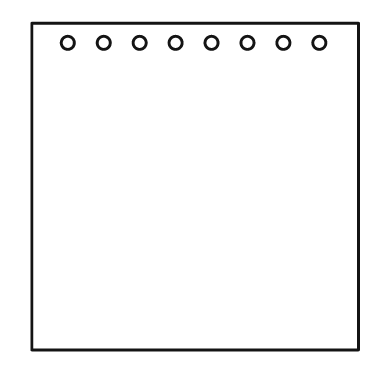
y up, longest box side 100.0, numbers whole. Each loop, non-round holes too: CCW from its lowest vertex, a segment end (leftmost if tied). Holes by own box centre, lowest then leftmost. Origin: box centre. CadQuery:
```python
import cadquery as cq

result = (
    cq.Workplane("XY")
    .moveTo(-50.0, -50.0)
    .lineTo(50.0, -50.0)
    .lineTo(50.0, 50.0)
    .lineTo(-50.0, 50.0)
    .close()
    .moveTo(-39.0, 44.0)
    .circle(2.0)
    .moveTo(-28.0, 44.0)
    .circle(2.0)
    .moveTo(-17.0, 44.0)
    .circle(2.0)
    .moveTo(-6.0, 44.0)
    .circle(2.0)
    .moveTo(5.0, 44.0)
    .circle(2.0)
    .moveTo(16.0, 44.0)
    .circle(2.0)
    .moveTo(27.0, 44.0)
    .circle(2.0)
    .moveTo(38.0, 44.0)
    .circle(2.0)
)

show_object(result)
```